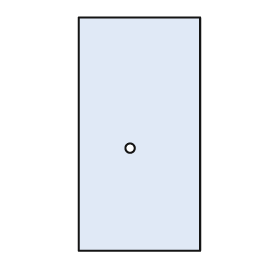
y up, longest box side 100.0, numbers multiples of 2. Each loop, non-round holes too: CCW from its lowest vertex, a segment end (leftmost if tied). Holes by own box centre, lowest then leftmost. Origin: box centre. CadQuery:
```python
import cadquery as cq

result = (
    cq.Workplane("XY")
    .moveTo(-26.0, -50.0)
    .lineTo(26.0, -50.0)
    .lineTo(26.0, 50.0)
    .lineTo(-26.0, 50.0)
    .close()
    .moveTo(-4.0, -6.0)
    .circle(2.0)
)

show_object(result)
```